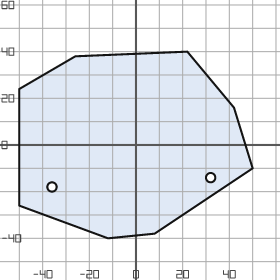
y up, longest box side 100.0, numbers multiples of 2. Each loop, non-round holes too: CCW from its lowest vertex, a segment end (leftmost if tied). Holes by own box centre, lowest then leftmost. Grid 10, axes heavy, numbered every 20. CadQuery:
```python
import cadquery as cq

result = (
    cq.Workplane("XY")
    .moveTo(-12.0, -40.0)
    .lineTo(8.0, -38.0)
    .lineTo(50.0, -10.0)
    .lineTo(42.0, 16.0)
    .lineTo(22.0, 40.0)
    .lineTo(-26.0, 38.0)
    .lineTo(-50.0, 24.0)
    .lineTo(-50.0, -26.0)
    .close()
    .moveTo(-36.0, -18.0)
    .circle(2.0)
    .moveTo(32.0, -14.0)
    .circle(2.0)
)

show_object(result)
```